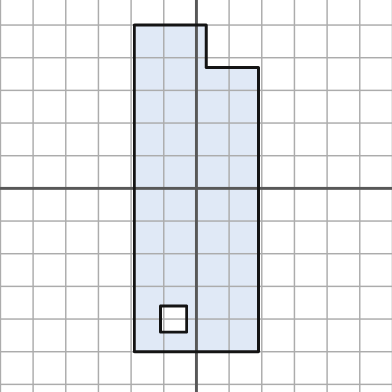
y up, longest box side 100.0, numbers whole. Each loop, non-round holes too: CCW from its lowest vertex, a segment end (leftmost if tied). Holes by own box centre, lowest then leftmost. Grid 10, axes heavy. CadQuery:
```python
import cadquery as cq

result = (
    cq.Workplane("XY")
    .moveTo(-19.0, -50.0)
    .lineTo(19.0, -50.0)
    .lineTo(19.0, 37.0)
    .lineTo(3.0, 37.0)
    .lineTo(3.0, 50.0)
    .lineTo(-19.0, 50.0)
    .close()
    .moveTo(-11.0, -44.0)
    .lineTo(-3.0, -44.0)
    .lineTo(-3.0, -36.0)
    .lineTo(-11.0, -36.0)
    .close()
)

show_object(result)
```